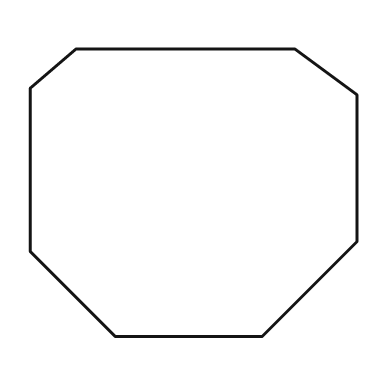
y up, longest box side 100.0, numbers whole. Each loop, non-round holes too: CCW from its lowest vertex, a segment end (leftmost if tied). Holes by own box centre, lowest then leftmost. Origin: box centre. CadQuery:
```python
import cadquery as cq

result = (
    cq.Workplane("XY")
    .moveTo(-24.0, -44.0)
    .lineTo(21.0, -44.0)
    .lineTo(50.0, -15.0)
    .lineTo(50.0, 30.0)
    .lineTo(31.0, 44.0)
    .lineTo(-36.0, 44.0)
    .lineTo(-50.0, 32.0)
    .lineTo(-50.0, -18.0)
    .close()
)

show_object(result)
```